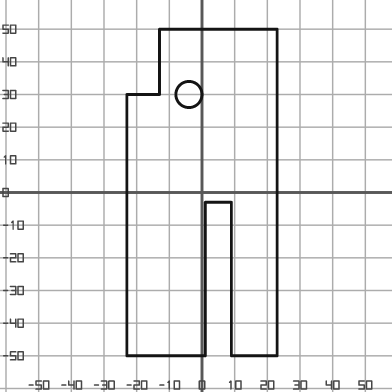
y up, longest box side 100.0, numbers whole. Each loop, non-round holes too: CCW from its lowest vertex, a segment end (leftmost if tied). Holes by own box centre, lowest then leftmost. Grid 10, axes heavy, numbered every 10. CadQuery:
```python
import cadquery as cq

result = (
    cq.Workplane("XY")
    .moveTo(-23.0, -50.0)
    .lineTo(1.0, -50.0)
    .lineTo(1.0, -3.0)
    .lineTo(9.0, -3.0)
    .lineTo(9.0, -50.0)
    .lineTo(23.0, -50.0)
    .lineTo(23.0, 50.0)
    .lineTo(-13.0, 50.0)
    .lineTo(-13.0, 30.0)
    .lineTo(-23.0, 30.0)
    .close()
    .moveTo(-4.0, 30.0)
    .circle(4.0)
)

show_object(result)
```